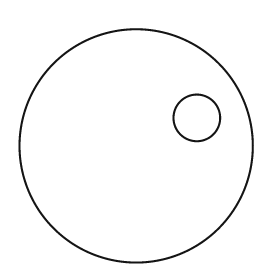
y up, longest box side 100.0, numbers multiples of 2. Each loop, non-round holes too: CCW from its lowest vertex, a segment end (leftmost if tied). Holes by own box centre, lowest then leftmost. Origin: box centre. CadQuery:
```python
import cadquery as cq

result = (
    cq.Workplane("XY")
    .moveTo(0.0, 0.0)
    .circle(50.0)
    .moveTo(26.0, 12.0)
    .circle(10.0)
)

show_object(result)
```